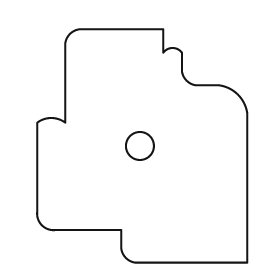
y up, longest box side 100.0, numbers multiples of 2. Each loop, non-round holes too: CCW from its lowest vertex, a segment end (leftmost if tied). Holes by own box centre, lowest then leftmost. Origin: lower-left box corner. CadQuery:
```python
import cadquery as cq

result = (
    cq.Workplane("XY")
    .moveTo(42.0, 0.0)
    .lineTo(90.0, 0.0)
    .lineTo(90.0, 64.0)
    .threePointArc((86.0, 72.0), (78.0, 76.0))
    .lineTo(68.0, 76.0)
    .threePointArc((64.0, 78.0), (62.0, 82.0))
    .lineTo(62.0, 90.0)
    .threePointArc((58.0, 92.0), (54.0, 90.0))
    .lineTo(54.0, 100.0)
    .lineTo(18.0, 100.0)
    .threePointArc((14.0, 98.0), (12.0, 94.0))
    .lineTo(12.0, 60.0)
    .threePointArc((6.0, 62.0), (0.0, 60.0))
    .lineTo(0.0, 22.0)
    .threePointArc((2.0, 16.0), (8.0, 14.0))
    .lineTo(36.0, 14.0)
    .lineTo(36.0, 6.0)
    .threePointArc((38.0, 2.0), (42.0, 0.0))
    .close()
    .moveTo(44.0, 50.0)
    .circle(6.0)
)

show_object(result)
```